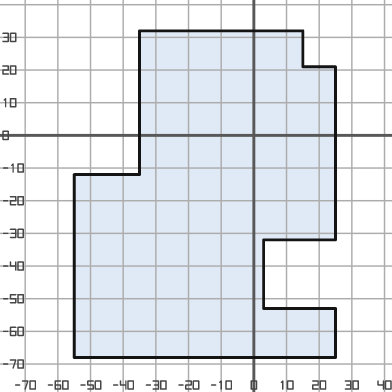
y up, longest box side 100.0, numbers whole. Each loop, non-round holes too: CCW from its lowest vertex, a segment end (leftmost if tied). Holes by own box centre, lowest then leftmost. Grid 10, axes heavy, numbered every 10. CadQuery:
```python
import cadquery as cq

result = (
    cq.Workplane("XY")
    .moveTo(-55.0, -68.0)
    .lineTo(25.0, -68.0)
    .lineTo(25.0, -53.0)
    .lineTo(3.0, -53.0)
    .lineTo(3.0, -32.0)
    .lineTo(25.0, -32.0)
    .lineTo(25.0, 21.0)
    .lineTo(15.0, 21.0)
    .lineTo(15.0, 32.0)
    .lineTo(-35.0, 32.0)
    .lineTo(-35.0, -12.0)
    .lineTo(-55.0, -12.0)
    .close()
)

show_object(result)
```